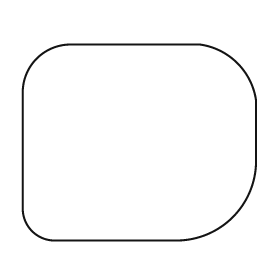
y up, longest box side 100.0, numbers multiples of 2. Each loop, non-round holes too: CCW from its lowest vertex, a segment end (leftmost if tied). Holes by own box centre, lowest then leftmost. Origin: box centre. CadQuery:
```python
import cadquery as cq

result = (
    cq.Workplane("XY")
    .moveTo(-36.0, -42.0)
    .lineTo(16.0, -42.0)
    .threePointArc((40.0, -32.0), (50.0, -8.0))
    .lineTo(50.0, 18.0)
    .threePointArc((42.0, 34.0), (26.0, 42.0))
    .lineTo(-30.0, 42.0)
    .threePointArc((-44.0, 36.0), (-50.0, 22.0))
    .lineTo(-50.0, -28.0)
    .threePointArc((-46.0, -38.0), (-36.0, -42.0))
    .close()
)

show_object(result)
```